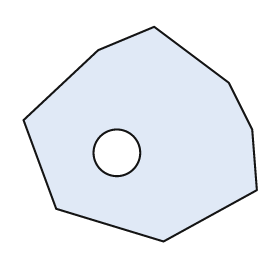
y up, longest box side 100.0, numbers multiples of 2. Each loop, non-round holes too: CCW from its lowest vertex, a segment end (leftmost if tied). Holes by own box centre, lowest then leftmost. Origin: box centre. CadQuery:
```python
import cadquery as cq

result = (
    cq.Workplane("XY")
    .moveTo(10.0, -46.0)
    .lineTo(50.0, -24.0)
    .lineTo(48.0, 2.0)
    .lineTo(38.0, 22.0)
    .lineTo(6.0, 46.0)
    .lineTo(-18.0, 36.0)
    .lineTo(-50.0, 6.0)
    .lineTo(-36.0, -32.0)
    .close()
    .moveTo(-10.0, -8.0)
    .circle(10.0)
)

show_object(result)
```